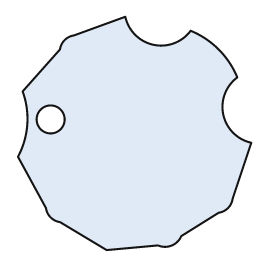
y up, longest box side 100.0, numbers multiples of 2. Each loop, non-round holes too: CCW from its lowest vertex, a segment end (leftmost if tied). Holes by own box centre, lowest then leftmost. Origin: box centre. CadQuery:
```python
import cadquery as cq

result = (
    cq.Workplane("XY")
    .moveTo(-12.0, -50.0)
    .lineTo(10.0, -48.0)
    .threePointArc((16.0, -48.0), (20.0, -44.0))
    .lineTo(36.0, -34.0)
    .threePointArc((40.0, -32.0), (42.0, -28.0))
    .lineTo(50.0, -4.0)
    .threePointArc((38.0, 8.0), (44.0, 24.0))
    .threePointArc((36.0, 36.0), (24.0, 44.0))
    .threePointArc((8.0, 38.0), (-4.0, 50.0))
    .lineTo(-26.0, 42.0)
    .threePointArc((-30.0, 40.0), (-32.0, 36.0))
    .lineTo(-48.0, 18.0)
    .threePointArc((-46.0, 4.0), (-50.0, -10.0))
    .lineTo(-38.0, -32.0)
    .threePointArc((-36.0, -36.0), (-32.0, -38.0))
    .close()
    .moveTo(-36.0, 6.0)
    .circle(6.0)
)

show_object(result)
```